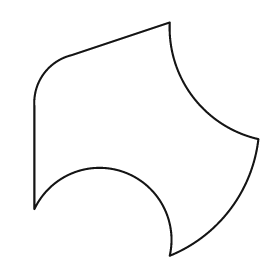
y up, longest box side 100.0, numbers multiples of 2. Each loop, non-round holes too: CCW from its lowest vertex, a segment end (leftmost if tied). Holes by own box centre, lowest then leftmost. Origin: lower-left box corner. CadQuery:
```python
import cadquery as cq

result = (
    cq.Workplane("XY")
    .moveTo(58.0, 0.0)
    .threePointArc((84.0, 20.0), (96.0, 50.0))
    .threePointArc((68.0, 68.0), (58.0, 100.0))
    .lineTo(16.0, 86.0)
    .threePointArc((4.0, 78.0), (0.0, 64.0))
    .lineTo(0.0, 20.0)
    .threePointArc((38.0, 36.0), (58.0, 0.0))
    .close()
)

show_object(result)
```